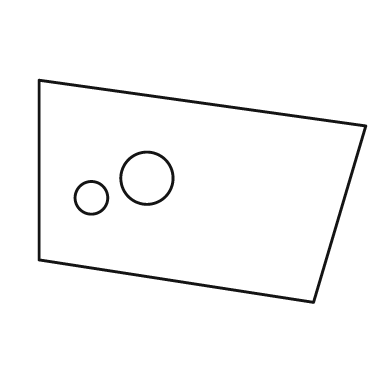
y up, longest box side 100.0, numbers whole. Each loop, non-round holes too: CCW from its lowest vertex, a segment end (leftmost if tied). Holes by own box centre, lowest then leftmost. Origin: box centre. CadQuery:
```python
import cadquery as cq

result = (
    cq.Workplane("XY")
    .moveTo(34.0, -34.0)
    .lineTo(50.0, 20.0)
    .lineTo(-50.0, 34.0)
    .lineTo(-50.0, -21.0)
    .close()
    .moveTo(-34.0, -2.0)
    .circle(5.0)
    .moveTo(-17.0, 4.0)
    .circle(8.0)
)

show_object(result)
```